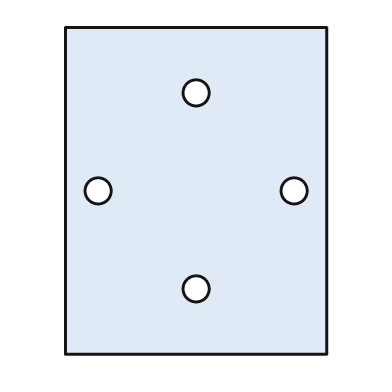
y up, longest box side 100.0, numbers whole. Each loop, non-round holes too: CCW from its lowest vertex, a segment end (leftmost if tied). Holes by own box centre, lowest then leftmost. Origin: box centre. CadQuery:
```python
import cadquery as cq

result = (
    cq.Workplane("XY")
    .moveTo(-40.0, -50.0)
    .lineTo(40.0, -50.0)
    .lineTo(40.0, 50.0)
    .lineTo(-40.0, 50.0)
    .close()
    .moveTo(0.0, -30.0)
    .circle(4.0)
    .moveTo(-30.0, 0.0)
    .circle(4.0)
    .moveTo(30.0, 0.0)
    .circle(4.0)
    .moveTo(0.0, 30.0)
    .circle(4.0)
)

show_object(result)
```